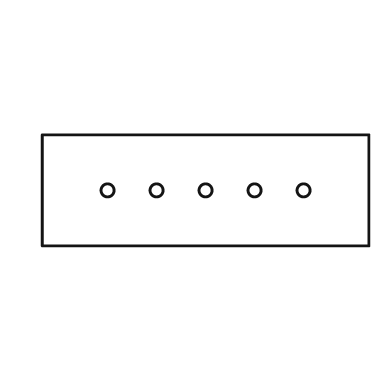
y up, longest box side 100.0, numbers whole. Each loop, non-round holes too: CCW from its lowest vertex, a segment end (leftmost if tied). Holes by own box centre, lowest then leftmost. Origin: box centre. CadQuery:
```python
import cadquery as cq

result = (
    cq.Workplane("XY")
    .moveTo(-50.0, -17.0)
    .lineTo(50.0, -17.0)
    .lineTo(50.0, 17.0)
    .lineTo(-50.0, 17.0)
    .close()
    .moveTo(-30.0, 0.0)
    .circle(2.0)
    .moveTo(-15.0, 0.0)
    .circle(2.0)
    .moveTo(0.0, 0.0)
    .circle(2.0)
    .moveTo(15.0, 0.0)
    .circle(2.0)
    .moveTo(30.0, 0.0)
    .circle(2.0)
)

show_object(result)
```